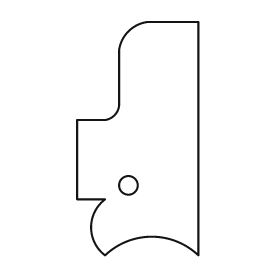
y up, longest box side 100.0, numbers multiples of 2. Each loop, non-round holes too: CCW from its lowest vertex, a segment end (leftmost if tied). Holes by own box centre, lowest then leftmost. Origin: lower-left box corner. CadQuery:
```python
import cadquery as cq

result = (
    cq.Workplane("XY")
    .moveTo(12.0, 0.0)
    .threePointArc((32.0, 8.0), (52.0, 0.0))
    .lineTo(52.0, 100.0)
    .lineTo(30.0, 100.0)
    .threePointArc((22.0, 96.0), (18.0, 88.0))
    .lineTo(18.0, 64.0)
    .threePointArc((16.0, 60.0), (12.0, 58.0))
    .lineTo(0.0, 58.0)
    .lineTo(0.0, 24.0)
    .lineTo(12.0, 24.0)
    .threePointArc((6.0, 12.0), (12.0, 0.0))
    .close()
    .moveTo(22.0, 30.0)
    .circle(4.0)
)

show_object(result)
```